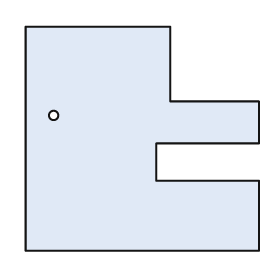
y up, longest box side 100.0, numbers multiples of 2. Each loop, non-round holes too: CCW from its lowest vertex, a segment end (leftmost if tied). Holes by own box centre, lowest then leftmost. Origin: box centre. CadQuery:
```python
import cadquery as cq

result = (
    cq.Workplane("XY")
    .moveTo(-50.0, -48.0)
    .lineTo(50.0, -48.0)
    .lineTo(50.0, -18.0)
    .lineTo(6.0, -18.0)
    .lineTo(6.0, -2.0)
    .lineTo(50.0, -2.0)
    .lineTo(50.0, 16.0)
    .lineTo(12.0, 16.0)
    .lineTo(12.0, 48.0)
    .lineTo(-50.0, 48.0)
    .close()
    .moveTo(-38.0, 10.0)
    .circle(2.0)
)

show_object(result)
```